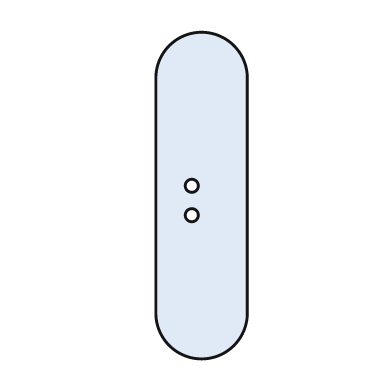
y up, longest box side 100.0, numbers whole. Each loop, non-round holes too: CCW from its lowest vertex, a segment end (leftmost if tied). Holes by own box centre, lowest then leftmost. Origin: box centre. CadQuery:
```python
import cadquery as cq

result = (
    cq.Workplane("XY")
    .moveTo(-14.0, -36.0)
    .threePointArc((0.0, -50.0), (14.0, -36.0))
    .lineTo(14.0, 36.0)
    .threePointArc((0.0, 50.0), (-14.0, 36.0))
    .close()
    .moveTo(-3.0, -6.0)
    .circle(2.0)
    .moveTo(-3.0, 3.0)
    .circle(2.0)
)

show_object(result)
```